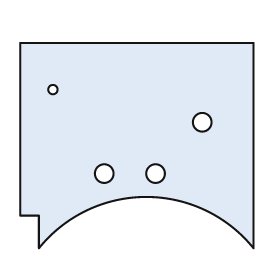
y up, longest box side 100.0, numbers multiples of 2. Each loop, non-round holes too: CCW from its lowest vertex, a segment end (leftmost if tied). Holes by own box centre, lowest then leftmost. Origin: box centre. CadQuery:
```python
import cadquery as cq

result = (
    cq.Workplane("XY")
    .moveTo(-42.0, -44.0)
    .threePointArc((4.0, -22.0), (50.0, -44.0))
    .lineTo(50.0, 44.0)
    .lineTo(-50.0, 44.0)
    .lineTo(-50.0, -30.0)
    .lineTo(-42.0, -30.0)
    .close()
    .moveTo(-14.0, -12.0)
    .circle(4.0)
    .moveTo(8.0, -12.0)
    .circle(4.0)
    .moveTo(28.0, 10.0)
    .circle(4.0)
    .moveTo(-36.0, 24.0)
    .circle(2.0)
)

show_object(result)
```